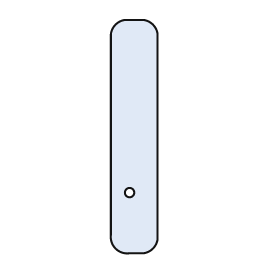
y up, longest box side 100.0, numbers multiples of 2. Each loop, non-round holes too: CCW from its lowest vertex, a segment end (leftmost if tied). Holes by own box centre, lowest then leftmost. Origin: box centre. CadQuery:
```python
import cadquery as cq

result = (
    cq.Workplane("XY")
    .moveTo(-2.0, -50.0)
    .lineTo(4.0, -50.0)
    .threePointArc((8.0, -48.0), (10.0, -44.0))
    .lineTo(10.0, 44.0)
    .threePointArc((8.0, 48.0), (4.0, 50.0))
    .lineTo(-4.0, 50.0)
    .threePointArc((-8.0, 48.0), (-10.0, 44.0))
    .lineTo(-10.0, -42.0)
    .threePointArc((-8.0, -48.0), (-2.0, -50.0))
    .close()
    .moveTo(-2.0, -24.0)
    .circle(2.0)
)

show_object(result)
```